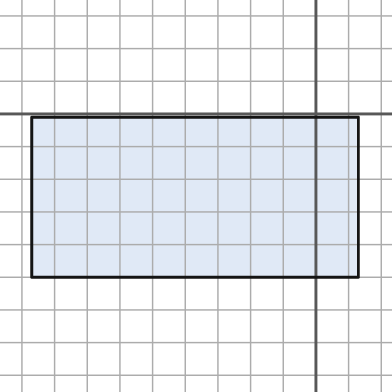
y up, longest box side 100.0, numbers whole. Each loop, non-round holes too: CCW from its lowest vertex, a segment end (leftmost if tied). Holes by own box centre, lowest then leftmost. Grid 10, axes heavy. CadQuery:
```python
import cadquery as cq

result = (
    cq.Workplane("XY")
    .moveTo(-87.0, -50.0)
    .lineTo(13.0, -50.0)
    .lineTo(13.0, -1.0)
    .lineTo(-87.0, -1.0)
    .close()
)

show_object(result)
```